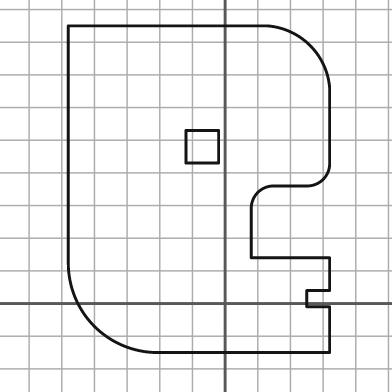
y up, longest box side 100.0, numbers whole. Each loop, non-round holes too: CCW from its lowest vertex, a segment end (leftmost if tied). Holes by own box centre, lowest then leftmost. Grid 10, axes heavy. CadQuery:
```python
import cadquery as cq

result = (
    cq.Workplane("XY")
    .moveTo(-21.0, -15.0)
    .lineTo(32.0, -15.0)
    .lineTo(32.0, -1.0)
    .lineTo(25.0, -1.0)
    .lineTo(25.0, 4.0)
    .lineTo(32.0, 4.0)
    .lineTo(32.0, 14.0)
    .lineTo(8.0, 14.0)
    .lineTo(8.0, 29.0)
    .threePointArc((10.0, 34.0), (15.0, 36.0))
    .lineTo(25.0, 36.0)
    .threePointArc((30.0, 38.0), (32.0, 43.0))
    .lineTo(32.0, 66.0)
    .threePointArc((26.0, 79.0), (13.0, 85.0))
    .lineTo(-48.0, 85.0)
    .lineTo(-48.0, 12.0)
    .threePointArc((-40.0, -7.0), (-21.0, -15.0))
    .close()
    .moveTo(-12.0, 43.0)
    .lineTo(-2.0, 43.0)
    .lineTo(-2.0, 53.0)
    .lineTo(-12.0, 53.0)
    .close()
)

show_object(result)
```